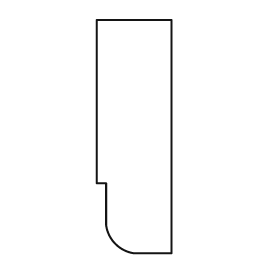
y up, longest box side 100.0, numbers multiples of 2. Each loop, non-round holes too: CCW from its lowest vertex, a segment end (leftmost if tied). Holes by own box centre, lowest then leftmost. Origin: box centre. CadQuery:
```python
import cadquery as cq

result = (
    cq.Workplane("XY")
    .moveTo(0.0, -50.0)
    .lineTo(16.0, -50.0)
    .lineTo(16.0, 50.0)
    .lineTo(-16.0, 50.0)
    .lineTo(-16.0, -20.0)
    .lineTo(-12.0, -20.0)
    .lineTo(-12.0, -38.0)
    .threePointArc((-8.0, -46.0), (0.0, -50.0))
    .close()
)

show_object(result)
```